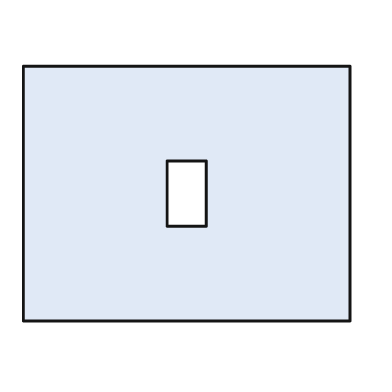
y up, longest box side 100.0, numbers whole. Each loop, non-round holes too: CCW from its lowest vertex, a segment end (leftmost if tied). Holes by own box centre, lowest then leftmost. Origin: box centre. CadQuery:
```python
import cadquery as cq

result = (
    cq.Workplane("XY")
    .moveTo(-50.0, -39.0)
    .lineTo(50.0, -39.0)
    .lineTo(50.0, 39.0)
    .lineTo(-50.0, 39.0)
    .close()
    .moveTo(-6.0, -10.0)
    .lineTo(6.0, -10.0)
    .lineTo(6.0, 10.0)
    .lineTo(-6.0, 10.0)
    .close()
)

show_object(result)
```